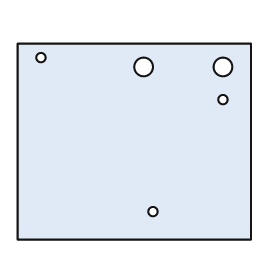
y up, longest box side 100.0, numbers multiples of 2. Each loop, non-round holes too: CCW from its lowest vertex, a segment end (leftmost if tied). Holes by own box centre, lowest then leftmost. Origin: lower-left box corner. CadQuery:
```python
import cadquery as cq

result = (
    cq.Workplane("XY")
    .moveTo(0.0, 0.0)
    .lineTo(100.0, 0.0)
    .lineTo(100.0, 84.0)
    .lineTo(0.0, 84.0)
    .close()
    .moveTo(58.0, 12.0)
    .circle(2.0)
    .moveTo(88.0, 60.0)
    .circle(2.0)
    .moveTo(54.0, 74.0)
    .circle(4.0)
    .moveTo(88.0, 74.0)
    .circle(4.0)
    .moveTo(10.0, 78.0)
    .circle(2.0)
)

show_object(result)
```